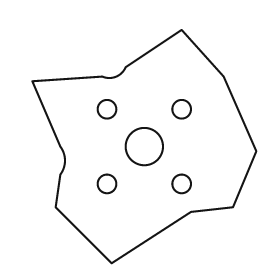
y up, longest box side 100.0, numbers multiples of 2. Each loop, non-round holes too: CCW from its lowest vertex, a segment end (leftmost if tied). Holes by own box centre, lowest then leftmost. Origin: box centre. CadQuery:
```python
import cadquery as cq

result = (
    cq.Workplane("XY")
    .moveTo(-14.0, -50.0)
    .lineTo(20.0, -28.0)
    .lineTo(38.0, -26.0)
    .lineTo(48.0, -2.0)
    .lineTo(34.0, 30.0)
    .lineTo(16.0, 50.0)
    .lineTo(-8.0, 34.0)
    .threePointArc((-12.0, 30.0), (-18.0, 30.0))
    .lineTo(-48.0, 28.0)
    .lineTo(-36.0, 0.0)
    .threePointArc((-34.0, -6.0), (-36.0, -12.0))
    .lineTo(-38.0, -26.0)
    .close()
    .moveTo(-16.0, -16.0)
    .circle(4.0)
    .moveTo(16.0, -16.0)
    .circle(4.0)
    .moveTo(0.0, 0.0)
    .circle(8.0)
    .moveTo(-16.0, 16.0)
    .circle(4.0)
    .moveTo(16.0, 16.0)
    .circle(4.0)
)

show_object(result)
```